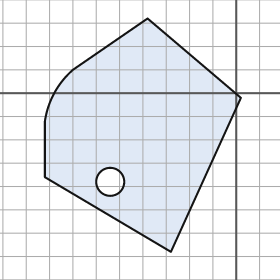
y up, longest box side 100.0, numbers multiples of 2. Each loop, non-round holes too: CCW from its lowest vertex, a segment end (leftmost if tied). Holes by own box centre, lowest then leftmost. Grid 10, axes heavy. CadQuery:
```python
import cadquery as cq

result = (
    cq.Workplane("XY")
    .moveTo(-28.0, -68.0)
    .lineTo(2.0, -2.0)
    .lineTo(-38.0, 32.0)
    .lineTo(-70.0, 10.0)
    .threePointArc((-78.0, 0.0), (-82.0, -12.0))
    .lineTo(-82.0, -36.0)
    .close()
    .moveTo(-54.0, -38.0)
    .circle(6.0)
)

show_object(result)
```